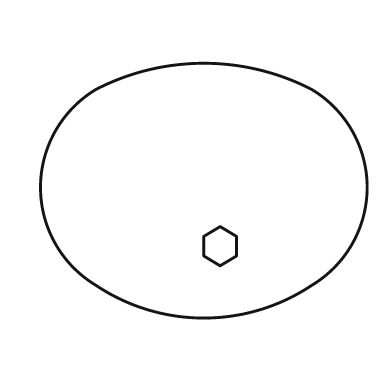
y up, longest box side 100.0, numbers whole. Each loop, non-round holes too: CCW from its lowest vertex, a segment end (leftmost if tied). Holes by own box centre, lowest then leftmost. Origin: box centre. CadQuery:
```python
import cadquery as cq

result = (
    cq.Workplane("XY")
    .moveTo(-33.0, -29.0)
    .threePointArc((0.0, -39.0), (33.0, -29.0))
    .threePointArc((50.0, 1.0), (33.0, 31.0))
    .threePointArc((0.0, 39.0), (-33.0, 31.0))
    .threePointArc((-50.0, 1.0), (-33.0, -29.0))
    .close()
    .moveTo(5.0, -23.0)
    .lineTo(10.0, -20.0)
    .lineTo(10.0, -14.0)
    .lineTo(5.0, -11.0)
    .lineTo(0.0, -14.0)
    .lineTo(0.0, -20.0)
    .close()
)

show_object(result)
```